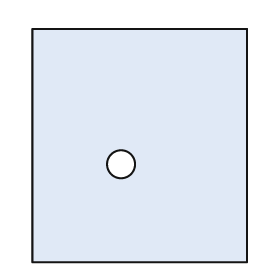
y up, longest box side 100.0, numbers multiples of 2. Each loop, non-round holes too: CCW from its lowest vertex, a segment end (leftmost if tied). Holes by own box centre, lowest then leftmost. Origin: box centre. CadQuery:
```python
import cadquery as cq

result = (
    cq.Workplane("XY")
    .moveTo(-46.0, -50.0)
    .lineTo(46.0, -50.0)
    .lineTo(46.0, 50.0)
    .lineTo(-46.0, 50.0)
    .close()
    .moveTo(-8.0, -8.0)
    .circle(6.0)
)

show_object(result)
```